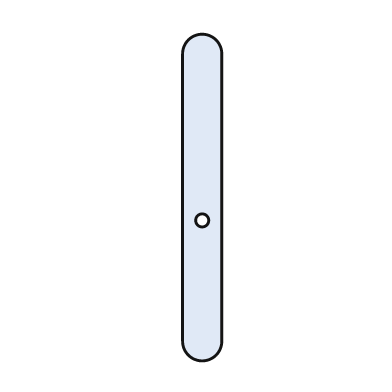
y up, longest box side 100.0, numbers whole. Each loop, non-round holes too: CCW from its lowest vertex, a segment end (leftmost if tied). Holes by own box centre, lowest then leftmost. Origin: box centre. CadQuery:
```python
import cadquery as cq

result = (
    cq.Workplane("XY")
    .moveTo(-6.0, -44.0)
    .threePointArc((0.0, -50.0), (6.0, -44.0))
    .lineTo(6.0, 44.0)
    .threePointArc((0.0, 50.0), (-6.0, 44.0))
    .close()
    .moveTo(0.0, -7.0)
    .circle(2.0)
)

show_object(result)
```